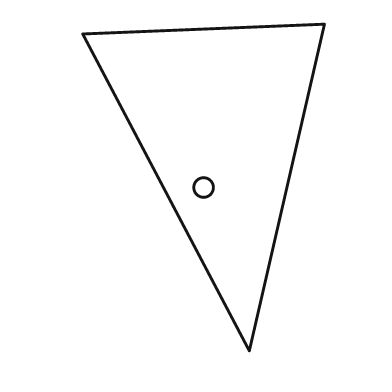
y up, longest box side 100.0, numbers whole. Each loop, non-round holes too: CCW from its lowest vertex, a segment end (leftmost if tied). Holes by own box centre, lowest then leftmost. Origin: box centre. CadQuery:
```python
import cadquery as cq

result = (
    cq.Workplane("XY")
    .moveTo(14.0, -50.0)
    .lineTo(37.0, 50.0)
    .lineTo(-37.0, 47.0)
    .close()
    .moveTo(0.0, 0.0)
    .circle(3.0)
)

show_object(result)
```